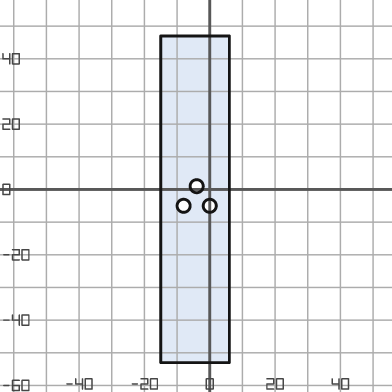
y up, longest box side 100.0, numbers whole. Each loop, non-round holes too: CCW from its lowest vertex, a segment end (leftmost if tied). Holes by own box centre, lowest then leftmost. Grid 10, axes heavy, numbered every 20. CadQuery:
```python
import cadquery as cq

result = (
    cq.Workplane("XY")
    .moveTo(-15.0, -53.0)
    .lineTo(6.0, -53.0)
    .lineTo(6.0, 47.0)
    .lineTo(-15.0, 47.0)
    .close()
    .moveTo(-8.0, -5.0)
    .circle(2.0)
    .moveTo(0.0, -5.0)
    .circle(2.0)
    .moveTo(-4.0, 1.0)
    .circle(2.0)
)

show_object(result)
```